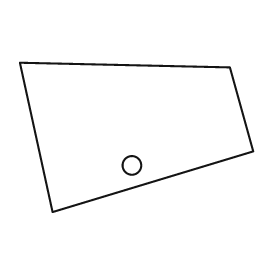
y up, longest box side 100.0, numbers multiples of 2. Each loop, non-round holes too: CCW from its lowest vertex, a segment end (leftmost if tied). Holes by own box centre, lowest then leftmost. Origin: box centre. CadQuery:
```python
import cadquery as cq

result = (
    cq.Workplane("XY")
    .moveTo(-36.0, -32.0)
    .lineTo(50.0, -6.0)
    .lineTo(40.0, 30.0)
    .lineTo(-50.0, 32.0)
    .close()
    .moveTo(-2.0, -12.0)
    .circle(4.0)
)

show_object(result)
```